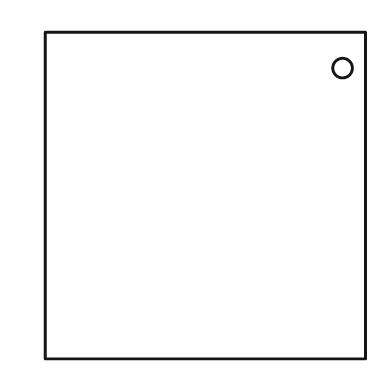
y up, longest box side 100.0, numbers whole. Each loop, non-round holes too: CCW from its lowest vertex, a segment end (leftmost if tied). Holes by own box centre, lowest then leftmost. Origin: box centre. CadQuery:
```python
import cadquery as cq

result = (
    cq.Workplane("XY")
    .moveTo(-49.0, -50.0)
    .lineTo(49.0, -50.0)
    .lineTo(49.0, 50.0)
    .lineTo(-49.0, 50.0)
    .close()
    .moveTo(42.0, 39.0)
    .circle(3.0)
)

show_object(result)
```